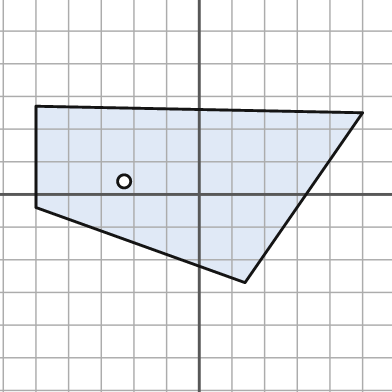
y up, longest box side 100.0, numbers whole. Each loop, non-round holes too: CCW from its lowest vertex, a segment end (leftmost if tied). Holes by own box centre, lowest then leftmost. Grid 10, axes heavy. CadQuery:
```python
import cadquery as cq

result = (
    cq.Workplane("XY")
    .moveTo(14.0, -27.0)
    .lineTo(50.0, 25.0)
    .lineTo(-50.0, 27.0)
    .lineTo(-50.0, -4.0)
    .close()
    .moveTo(-23.0, 4.0)
    .circle(2.0)
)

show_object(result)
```